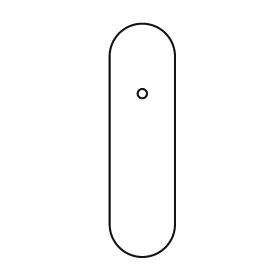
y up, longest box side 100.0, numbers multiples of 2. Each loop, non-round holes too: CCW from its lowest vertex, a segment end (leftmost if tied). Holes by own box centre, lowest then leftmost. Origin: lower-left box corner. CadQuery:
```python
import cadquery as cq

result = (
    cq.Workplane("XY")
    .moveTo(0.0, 14.0)
    .threePointArc((14.0, 0.0), (28.0, 14.0))
    .lineTo(28.0, 86.0)
    .threePointArc((14.0, 100.0), (0.0, 86.0))
    .close()
    .moveTo(14.0, 70.0)
    .circle(2.0)
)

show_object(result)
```